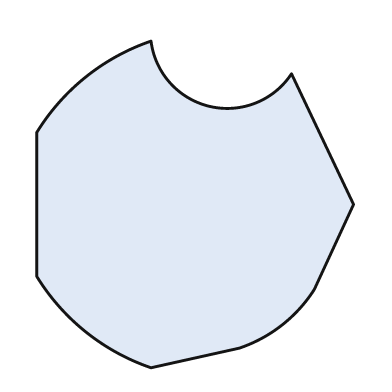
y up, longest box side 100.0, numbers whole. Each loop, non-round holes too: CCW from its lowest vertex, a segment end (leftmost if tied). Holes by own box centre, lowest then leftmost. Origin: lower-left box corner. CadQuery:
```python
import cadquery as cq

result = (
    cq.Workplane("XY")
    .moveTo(35.0, 0.0)
    .lineTo(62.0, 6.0)
    .threePointArc((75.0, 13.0), (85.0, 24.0))
    .lineTo(97.0, 50.0)
    .lineTo(78.0, 90.0)
    .threePointArc((53.0, 80.0), (35.0, 100.0))
    .threePointArc((15.0, 89.0), (0.0, 72.0))
    .lineTo(0.0, 28.0)
    .threePointArc((15.0, 11.0), (35.0, 0.0))
    .close()
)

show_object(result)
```